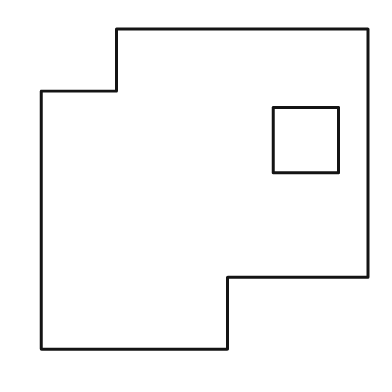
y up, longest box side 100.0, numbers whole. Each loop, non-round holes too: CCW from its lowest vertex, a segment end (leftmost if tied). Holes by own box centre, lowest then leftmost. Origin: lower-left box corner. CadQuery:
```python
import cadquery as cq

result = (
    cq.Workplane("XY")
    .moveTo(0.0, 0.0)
    .lineTo(57.0, 0.0)
    .lineTo(57.0, 22.0)
    .lineTo(100.0, 22.0)
    .lineTo(100.0, 98.0)
    .lineTo(23.0, 98.0)
    .lineTo(23.0, 79.0)
    .lineTo(0.0, 79.0)
    .close()
    .moveTo(71.0, 54.0)
    .lineTo(91.0, 54.0)
    .lineTo(91.0, 74.0)
    .lineTo(71.0, 74.0)
    .close()
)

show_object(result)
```